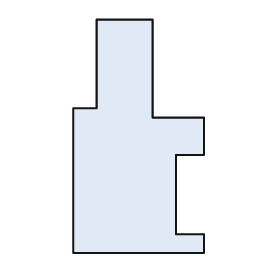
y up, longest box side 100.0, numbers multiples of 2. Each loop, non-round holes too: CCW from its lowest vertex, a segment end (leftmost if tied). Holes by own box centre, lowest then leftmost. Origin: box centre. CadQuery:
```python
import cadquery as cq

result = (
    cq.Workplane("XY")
    .moveTo(-28.0, -50.0)
    .lineTo(28.0, -50.0)
    .lineTo(28.0, -42.0)
    .lineTo(16.0, -42.0)
    .lineTo(16.0, -8.0)
    .lineTo(28.0, -8.0)
    .lineTo(28.0, 8.0)
    .lineTo(6.0, 8.0)
    .lineTo(6.0, 50.0)
    .lineTo(-18.0, 50.0)
    .lineTo(-18.0, 12.0)
    .lineTo(-28.0, 12.0)
    .close()
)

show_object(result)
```